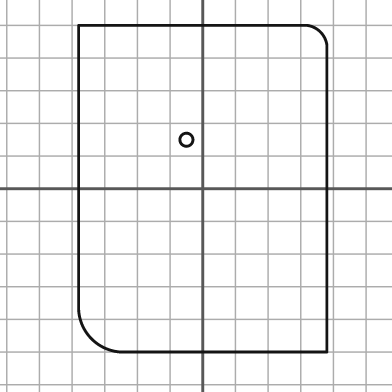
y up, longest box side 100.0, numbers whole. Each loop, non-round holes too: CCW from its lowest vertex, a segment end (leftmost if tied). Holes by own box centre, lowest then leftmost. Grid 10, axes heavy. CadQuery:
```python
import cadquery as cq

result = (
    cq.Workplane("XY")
    .moveTo(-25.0, -50.0)
    .lineTo(38.0, -50.0)
    .lineTo(38.0, 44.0)
    .threePointArc((36.0, 48.0), (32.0, 50.0))
    .lineTo(-38.0, 50.0)
    .lineTo(-38.0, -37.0)
    .threePointArc((-34.0, -46.0), (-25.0, -50.0))
    .close()
    .moveTo(-5.0, 15.0)
    .circle(2.0)
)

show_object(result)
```